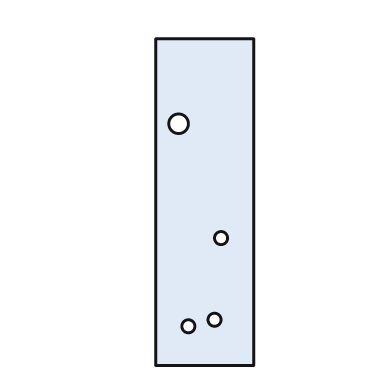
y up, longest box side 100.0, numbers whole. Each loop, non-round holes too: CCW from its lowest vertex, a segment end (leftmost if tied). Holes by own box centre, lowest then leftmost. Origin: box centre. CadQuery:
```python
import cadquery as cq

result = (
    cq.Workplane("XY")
    .moveTo(-15.0, -50.0)
    .lineTo(15.0, -50.0)
    .lineTo(15.0, 50.0)
    .lineTo(-15.0, 50.0)
    .close()
    .moveTo(-5.0, -38.0)
    .circle(2.0)
    .moveTo(3.0, -36.0)
    .circle(2.0)
    .moveTo(5.0, -11.0)
    .circle(2.0)
    .moveTo(-8.0, 24.0)
    .circle(3.0)
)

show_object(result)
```